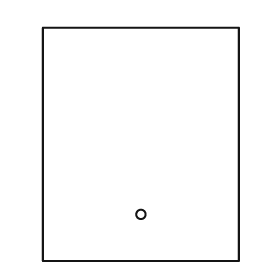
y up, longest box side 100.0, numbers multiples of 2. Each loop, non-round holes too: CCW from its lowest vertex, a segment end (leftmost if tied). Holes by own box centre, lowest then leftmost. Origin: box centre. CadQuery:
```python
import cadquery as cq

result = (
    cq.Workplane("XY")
    .moveTo(-42.0, -50.0)
    .lineTo(42.0, -50.0)
    .lineTo(42.0, 50.0)
    .lineTo(-42.0, 50.0)
    .close()
    .moveTo(0.0, -30.0)
    .circle(2.0)
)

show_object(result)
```